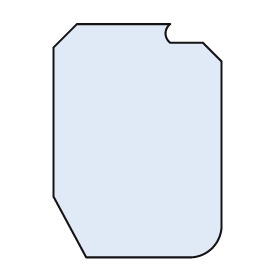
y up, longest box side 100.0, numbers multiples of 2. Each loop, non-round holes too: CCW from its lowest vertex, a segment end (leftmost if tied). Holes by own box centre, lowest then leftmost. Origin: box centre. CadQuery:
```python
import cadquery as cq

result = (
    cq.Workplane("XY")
    .moveTo(-22.0, -50.0)
    .lineTo(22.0, -50.0)
    .threePointArc((32.0, -46.0), (36.0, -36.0))
    .lineTo(36.0, 34.0)
    .lineTo(28.0, 42.0)
    .lineTo(14.0, 42.0)
    .threePointArc((12.0, 46.0), (14.0, 50.0))
    .lineTo(-26.0, 50.0)
    .lineTo(-36.0, 40.0)
    .lineTo(-36.0, -24.0)
    .close()
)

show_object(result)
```